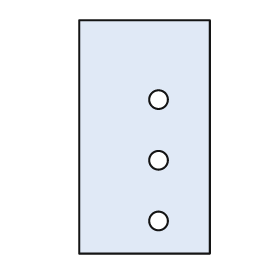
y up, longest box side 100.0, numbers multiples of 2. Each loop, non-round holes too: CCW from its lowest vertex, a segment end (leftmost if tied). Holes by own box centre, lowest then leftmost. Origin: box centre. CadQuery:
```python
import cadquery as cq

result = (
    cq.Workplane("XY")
    .moveTo(-28.0, -50.0)
    .lineTo(28.0, -50.0)
    .lineTo(28.0, 50.0)
    .lineTo(-28.0, 50.0)
    .close()
    .moveTo(6.0, -36.0)
    .circle(4.0)
    .moveTo(6.0, -10.0)
    .circle(4.0)
    .moveTo(6.0, 16.0)
    .circle(4.0)
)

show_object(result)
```